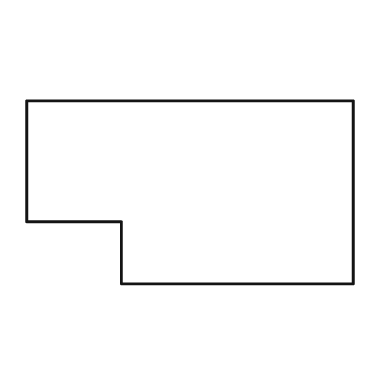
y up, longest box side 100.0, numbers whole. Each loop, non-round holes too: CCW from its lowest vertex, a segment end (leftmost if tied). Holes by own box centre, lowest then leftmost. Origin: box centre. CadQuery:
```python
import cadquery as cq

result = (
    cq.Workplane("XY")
    .moveTo(-21.0, -28.0)
    .lineTo(50.0, -28.0)
    .lineTo(50.0, 28.0)
    .lineTo(-50.0, 28.0)
    .lineTo(-50.0, -9.0)
    .lineTo(-21.0, -9.0)
    .close()
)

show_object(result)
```